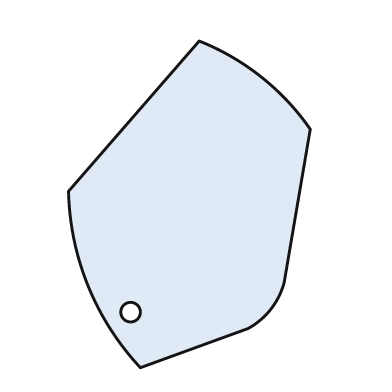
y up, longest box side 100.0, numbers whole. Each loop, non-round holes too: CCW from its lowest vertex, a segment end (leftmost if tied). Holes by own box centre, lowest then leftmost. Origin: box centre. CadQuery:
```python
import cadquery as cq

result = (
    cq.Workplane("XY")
    .moveTo(-15.0, -50.0)
    .lineTo(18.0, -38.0)
    .threePointArc((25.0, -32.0), (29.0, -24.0))
    .lineTo(37.0, 23.0)
    .threePointArc((22.0, 39.0), (3.0, 50.0))
    .lineTo(-37.0, 4.0)
    .threePointArc((-31.0, -25.0), (-15.0, -50.0))
    .close()
    .moveTo(-18.0, -33.0)
    .circle(3.0)
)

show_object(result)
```